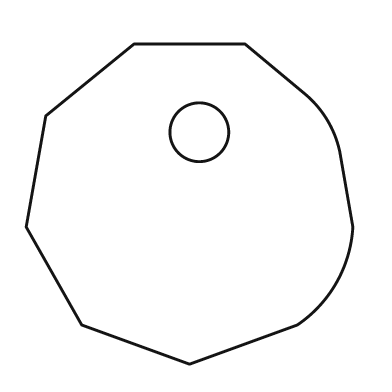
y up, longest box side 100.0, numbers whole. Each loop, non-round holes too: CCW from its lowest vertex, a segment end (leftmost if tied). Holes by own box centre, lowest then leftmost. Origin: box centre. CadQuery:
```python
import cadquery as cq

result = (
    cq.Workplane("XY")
    .moveTo(0.0, -49.0)
    .lineTo(33.0, -37.0)
    .threePointArc((45.0, -24.0), (50.0, -7.0))
    .lineTo(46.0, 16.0)
    .threePointArc((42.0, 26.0), (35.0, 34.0))
    .lineTo(17.0, 49.0)
    .lineTo(-17.0, 49.0)
    .lineTo(-44.0, 27.0)
    .lineTo(-50.0, -7.0)
    .lineTo(-33.0, -37.0)
    .close()
    .moveTo(3.0, 22.0)
    .circle(9.0)
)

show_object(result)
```